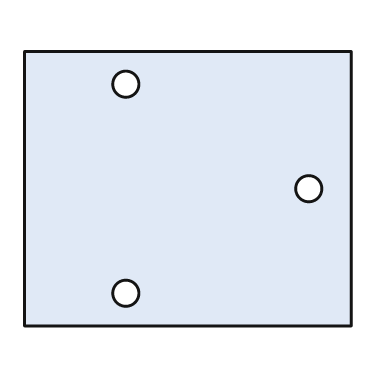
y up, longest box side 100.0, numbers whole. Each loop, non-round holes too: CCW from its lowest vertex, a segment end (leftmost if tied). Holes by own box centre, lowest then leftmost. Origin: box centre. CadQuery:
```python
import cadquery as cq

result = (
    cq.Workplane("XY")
    .moveTo(-50.0, -42.0)
    .lineTo(50.0, -42.0)
    .lineTo(50.0, 42.0)
    .lineTo(-50.0, 42.0)
    .close()
    .moveTo(-19.0, -32.0)
    .circle(4.0)
    .moveTo(37.0, 0.0)
    .circle(4.0)
    .moveTo(-19.0, 32.0)
    .circle(4.0)
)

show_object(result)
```